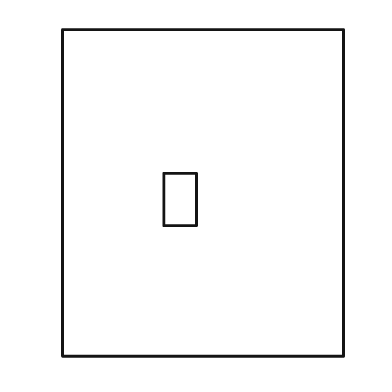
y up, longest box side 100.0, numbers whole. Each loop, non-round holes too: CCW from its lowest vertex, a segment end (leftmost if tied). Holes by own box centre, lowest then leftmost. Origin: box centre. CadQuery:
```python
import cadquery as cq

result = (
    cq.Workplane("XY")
    .moveTo(-43.0, -50.0)
    .lineTo(43.0, -50.0)
    .lineTo(43.0, 50.0)
    .lineTo(-43.0, 50.0)
    .close()
    .moveTo(-12.0, -10.0)
    .lineTo(-2.0, -10.0)
    .lineTo(-2.0, 6.0)
    .lineTo(-12.0, 6.0)
    .close()
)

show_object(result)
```